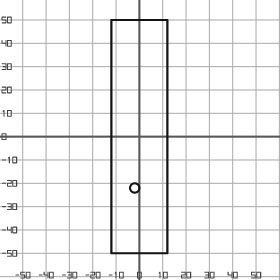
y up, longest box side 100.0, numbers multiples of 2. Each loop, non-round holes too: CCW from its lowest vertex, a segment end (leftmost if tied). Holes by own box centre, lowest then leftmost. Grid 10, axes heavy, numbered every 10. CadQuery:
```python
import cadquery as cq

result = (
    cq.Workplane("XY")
    .moveTo(-12.0, -50.0)
    .lineTo(12.0, -50.0)
    .lineTo(12.0, 50.0)
    .lineTo(-12.0, 50.0)
    .close()
    .moveTo(-2.0, -22.0)
    .circle(2.0)
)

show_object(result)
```